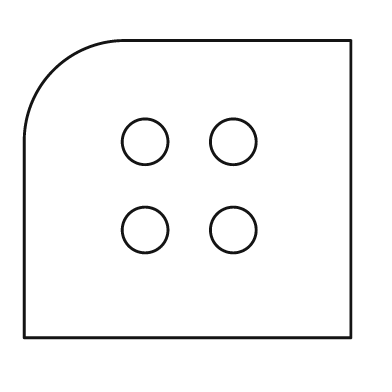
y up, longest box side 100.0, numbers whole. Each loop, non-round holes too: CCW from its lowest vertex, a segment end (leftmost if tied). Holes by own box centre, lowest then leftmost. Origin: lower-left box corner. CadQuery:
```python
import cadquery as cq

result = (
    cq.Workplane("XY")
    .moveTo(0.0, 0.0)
    .lineTo(100.0, 0.0)
    .lineTo(100.0, 91.0)
    .lineTo(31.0, 91.0)
    .threePointArc((9.0, 82.0), (0.0, 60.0))
    .close()
    .moveTo(37.0, 33.0)
    .circle(7.0)
    .moveTo(64.0, 33.0)
    .circle(7.0)
    .moveTo(37.0, 60.0)
    .circle(7.0)
    .moveTo(64.0, 60.0)
    .circle(7.0)
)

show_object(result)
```